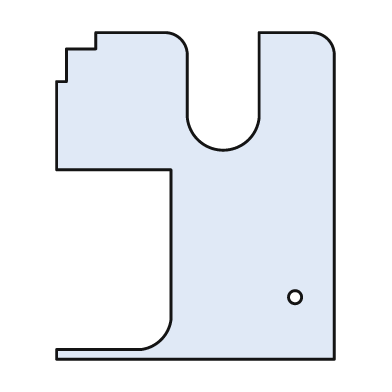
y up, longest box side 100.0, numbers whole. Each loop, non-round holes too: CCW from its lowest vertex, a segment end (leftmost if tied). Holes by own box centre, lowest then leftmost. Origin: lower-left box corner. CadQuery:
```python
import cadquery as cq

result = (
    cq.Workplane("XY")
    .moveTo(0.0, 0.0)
    .lineTo(85.0, 0.0)
    .lineTo(85.0, 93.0)
    .threePointArc((83.0, 98.0), (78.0, 100.0))
    .lineTo(62.0, 100.0)
    .lineTo(62.0, 74.0)
    .threePointArc((51.0, 64.0), (40.0, 74.0))
    .lineTo(40.0, 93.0)
    .threePointArc((38.0, 98.0), (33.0, 100.0))
    .lineTo(12.0, 100.0)
    .lineTo(12.0, 95.0)
    .lineTo(3.0, 95.0)
    .lineTo(3.0, 85.0)
    .lineTo(0.0, 85.0)
    .lineTo(0.0, 58.0)
    .lineTo(35.0, 58.0)
    .lineTo(35.0, 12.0)
    .threePointArc((32.0, 6.0), (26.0, 3.0))
    .lineTo(0.0, 3.0)
    .close()
    .moveTo(73.0, 19.0)
    .circle(2.0)
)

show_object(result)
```